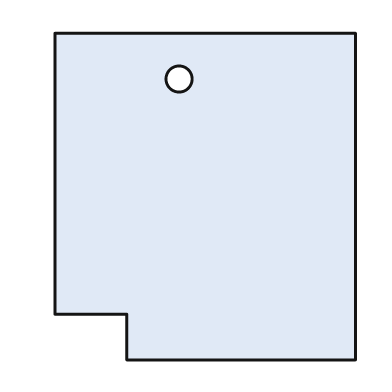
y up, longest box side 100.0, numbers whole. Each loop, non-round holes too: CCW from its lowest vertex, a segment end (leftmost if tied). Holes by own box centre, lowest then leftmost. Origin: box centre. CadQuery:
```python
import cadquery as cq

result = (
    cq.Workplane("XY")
    .moveTo(-24.0, -50.0)
    .lineTo(46.0, -50.0)
    .lineTo(46.0, 50.0)
    .lineTo(-46.0, 50.0)
    .lineTo(-46.0, -36.0)
    .lineTo(-24.0, -36.0)
    .close()
    .moveTo(-8.0, 36.0)
    .circle(4.0)
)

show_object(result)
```